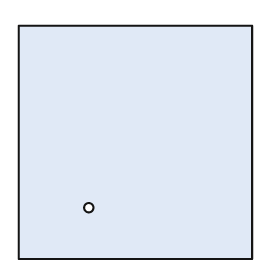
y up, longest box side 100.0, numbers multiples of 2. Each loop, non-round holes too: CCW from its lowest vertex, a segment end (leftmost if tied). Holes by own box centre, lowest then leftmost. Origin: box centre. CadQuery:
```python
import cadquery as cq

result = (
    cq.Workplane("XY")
    .moveTo(-50.0, -50.0)
    .lineTo(50.0, -50.0)
    .lineTo(50.0, 50.0)
    .lineTo(-50.0, 50.0)
    .close()
    .moveTo(-20.0, -28.0)
    .circle(2.0)
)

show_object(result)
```